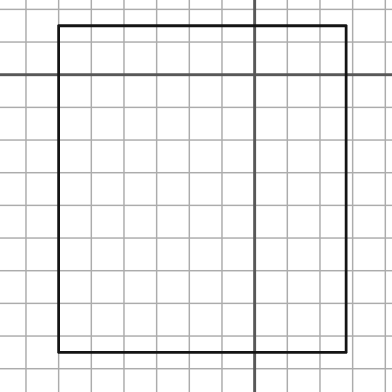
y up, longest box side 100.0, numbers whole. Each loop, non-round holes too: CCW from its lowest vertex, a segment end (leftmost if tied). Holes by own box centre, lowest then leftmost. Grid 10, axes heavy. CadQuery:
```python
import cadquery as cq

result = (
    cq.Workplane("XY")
    .moveTo(-60.0, -85.0)
    .lineTo(28.0, -85.0)
    .lineTo(28.0, 15.0)
    .lineTo(-60.0, 15.0)
    .close()
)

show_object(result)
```